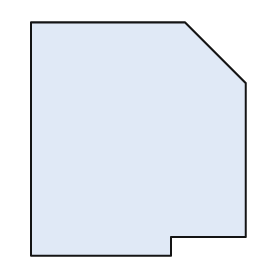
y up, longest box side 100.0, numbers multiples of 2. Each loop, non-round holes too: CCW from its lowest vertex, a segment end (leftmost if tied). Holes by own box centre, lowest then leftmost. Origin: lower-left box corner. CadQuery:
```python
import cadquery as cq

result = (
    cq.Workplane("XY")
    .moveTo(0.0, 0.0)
    .lineTo(60.0, 0.0)
    .lineTo(60.0, 8.0)
    .lineTo(92.0, 8.0)
    .lineTo(92.0, 74.0)
    .lineTo(66.0, 100.0)
    .lineTo(0.0, 100.0)
    .close()
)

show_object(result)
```